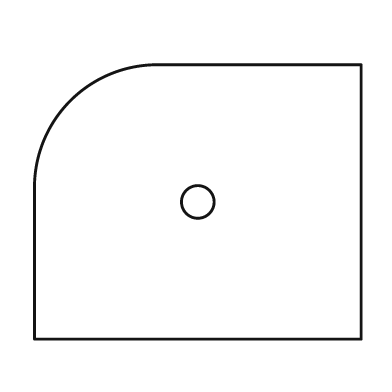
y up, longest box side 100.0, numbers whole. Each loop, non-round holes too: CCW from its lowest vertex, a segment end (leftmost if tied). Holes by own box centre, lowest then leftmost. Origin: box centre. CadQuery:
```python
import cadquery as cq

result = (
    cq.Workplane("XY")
    .moveTo(-50.0, -42.0)
    .lineTo(50.0, -42.0)
    .lineTo(50.0, 42.0)
    .lineTo(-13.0, 42.0)
    .threePointArc((-39.0, 31.0), (-50.0, 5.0))
    .close()
    .moveTo(0.0, 0.0)
    .circle(5.0)
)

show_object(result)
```